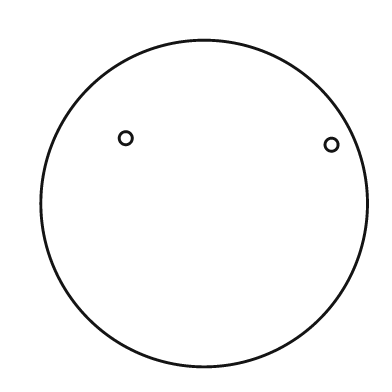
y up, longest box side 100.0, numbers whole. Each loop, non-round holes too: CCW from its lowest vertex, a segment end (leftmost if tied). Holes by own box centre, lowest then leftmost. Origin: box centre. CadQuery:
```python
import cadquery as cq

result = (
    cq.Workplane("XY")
    .moveTo(0.0, 0.0)
    .circle(50.0)
    .moveTo(39.0, 18.0)
    .circle(2.0)
    .moveTo(-24.0, 20.0)
    .circle(2.0)
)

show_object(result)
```